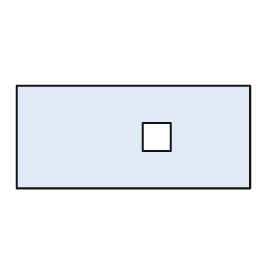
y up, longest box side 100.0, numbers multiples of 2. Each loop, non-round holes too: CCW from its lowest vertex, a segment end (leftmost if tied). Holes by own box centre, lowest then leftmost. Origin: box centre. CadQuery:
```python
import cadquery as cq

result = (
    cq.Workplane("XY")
    .moveTo(-50.0, -22.0)
    .lineTo(50.0, -22.0)
    .lineTo(50.0, 22.0)
    .lineTo(-50.0, 22.0)
    .close()
    .moveTo(4.0, -6.0)
    .lineTo(16.0, -6.0)
    .lineTo(16.0, 6.0)
    .lineTo(4.0, 6.0)
    .close()
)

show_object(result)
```